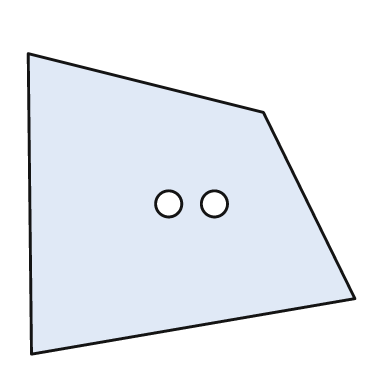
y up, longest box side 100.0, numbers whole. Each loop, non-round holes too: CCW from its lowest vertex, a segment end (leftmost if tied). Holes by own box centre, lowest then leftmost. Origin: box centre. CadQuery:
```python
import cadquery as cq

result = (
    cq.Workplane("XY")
    .moveTo(-49.0, -46.0)
    .lineTo(50.0, -29.0)
    .lineTo(22.0, 28.0)
    .lineTo(-50.0, 46.0)
    .close()
    .moveTo(-7.0, 0.0)
    .circle(4.0)
    .moveTo(7.0, 0.0)
    .circle(4.0)
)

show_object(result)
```